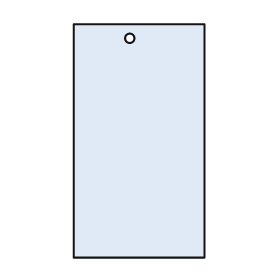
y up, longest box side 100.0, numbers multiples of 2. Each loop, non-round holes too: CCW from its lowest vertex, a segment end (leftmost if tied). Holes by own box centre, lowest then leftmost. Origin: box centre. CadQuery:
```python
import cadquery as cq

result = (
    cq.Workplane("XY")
    .moveTo(-28.0, -50.0)
    .lineTo(28.0, -50.0)
    .lineTo(28.0, 50.0)
    .lineTo(-28.0, 50.0)
    .close()
    .moveTo(-4.0, 44.0)
    .circle(2.0)
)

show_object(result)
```